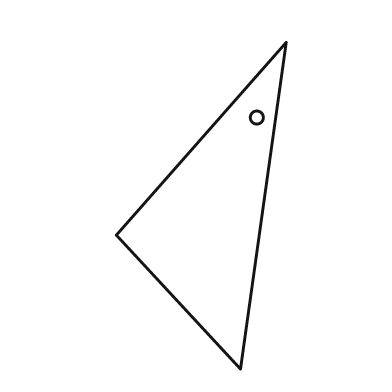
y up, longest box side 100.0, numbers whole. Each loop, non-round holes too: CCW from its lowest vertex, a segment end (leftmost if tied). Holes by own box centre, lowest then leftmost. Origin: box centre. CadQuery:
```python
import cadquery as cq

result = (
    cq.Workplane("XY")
    .moveTo(12.0, -50.0)
    .lineTo(26.0, 50.0)
    .lineTo(-26.0, -9.0)
    .close()
    .moveTo(17.0, 27.0)
    .circle(2.0)
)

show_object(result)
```